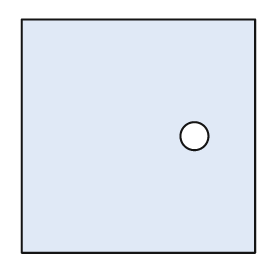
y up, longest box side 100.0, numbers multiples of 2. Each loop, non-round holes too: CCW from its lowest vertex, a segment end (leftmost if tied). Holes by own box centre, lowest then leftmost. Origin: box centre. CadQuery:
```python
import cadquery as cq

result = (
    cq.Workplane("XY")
    .moveTo(-50.0, -50.0)
    .lineTo(50.0, -50.0)
    .lineTo(50.0, 50.0)
    .lineTo(-50.0, 50.0)
    .close()
    .moveTo(24.0, 0.0)
    .circle(6.0)
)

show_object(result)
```